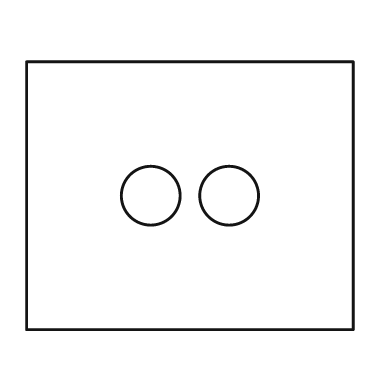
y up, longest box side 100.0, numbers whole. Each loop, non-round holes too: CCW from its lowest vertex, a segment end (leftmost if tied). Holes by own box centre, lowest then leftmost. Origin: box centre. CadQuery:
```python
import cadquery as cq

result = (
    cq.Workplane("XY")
    .moveTo(-50.0, -41.0)
    .lineTo(50.0, -41.0)
    .lineTo(50.0, 41.0)
    .lineTo(-50.0, 41.0)
    .close()
    .moveTo(-12.0, 0.0)
    .circle(9.0)
    .moveTo(12.0, 0.0)
    .circle(9.0)
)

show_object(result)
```